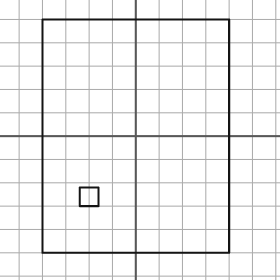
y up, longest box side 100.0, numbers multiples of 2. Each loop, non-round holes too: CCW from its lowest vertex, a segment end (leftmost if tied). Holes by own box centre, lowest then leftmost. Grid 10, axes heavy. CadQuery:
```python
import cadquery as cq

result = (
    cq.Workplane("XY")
    .moveTo(-40.0, -50.0)
    .lineTo(40.0, -50.0)
    .lineTo(40.0, 50.0)
    .lineTo(-40.0, 50.0)
    .close()
    .moveTo(-24.0, -30.0)
    .lineTo(-16.0, -30.0)
    .lineTo(-16.0, -22.0)
    .lineTo(-24.0, -22.0)
    .close()
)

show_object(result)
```